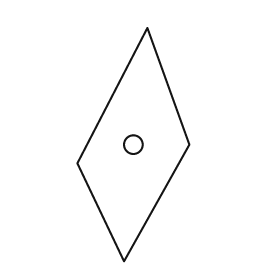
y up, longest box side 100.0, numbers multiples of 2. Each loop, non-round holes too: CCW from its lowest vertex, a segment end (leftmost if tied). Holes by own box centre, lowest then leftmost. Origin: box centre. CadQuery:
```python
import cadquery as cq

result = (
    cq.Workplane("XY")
    .moveTo(-4.0, -50.0)
    .lineTo(24.0, 0.0)
    .lineTo(6.0, 50.0)
    .lineTo(-24.0, -8.0)
    .close()
    .moveTo(0.0, 0.0)
    .circle(4.0)
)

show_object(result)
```